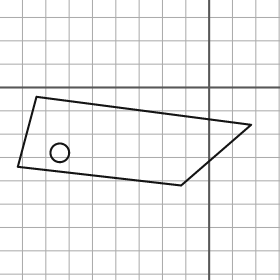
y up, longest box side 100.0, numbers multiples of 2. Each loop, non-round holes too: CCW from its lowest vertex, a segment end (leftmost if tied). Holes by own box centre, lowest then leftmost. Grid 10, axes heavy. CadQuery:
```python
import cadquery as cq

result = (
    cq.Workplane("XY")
    .moveTo(-12.0, -42.0)
    .lineTo(18.0, -16.0)
    .lineTo(-74.0, -4.0)
    .lineTo(-82.0, -34.0)
    .close()
    .moveTo(-64.0, -28.0)
    .circle(4.0)
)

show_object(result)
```